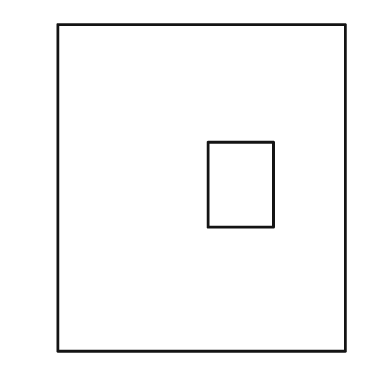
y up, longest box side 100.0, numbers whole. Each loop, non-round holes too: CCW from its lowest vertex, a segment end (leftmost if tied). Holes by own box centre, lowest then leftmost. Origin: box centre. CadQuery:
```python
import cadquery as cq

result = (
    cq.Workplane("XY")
    .moveTo(-44.0, -50.0)
    .lineTo(44.0, -50.0)
    .lineTo(44.0, 50.0)
    .lineTo(-44.0, 50.0)
    .close()
    .moveTo(2.0, -12.0)
    .lineTo(22.0, -12.0)
    .lineTo(22.0, 14.0)
    .lineTo(2.0, 14.0)
    .close()
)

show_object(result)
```